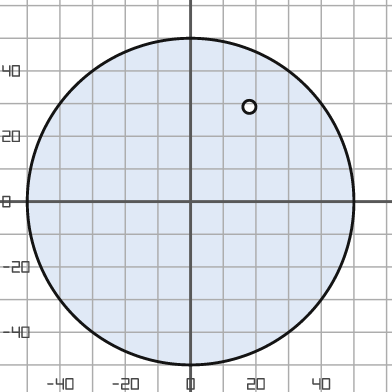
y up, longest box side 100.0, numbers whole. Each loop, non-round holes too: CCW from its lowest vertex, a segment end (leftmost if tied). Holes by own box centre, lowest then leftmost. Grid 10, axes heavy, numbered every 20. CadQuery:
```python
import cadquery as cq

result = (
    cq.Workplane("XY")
    .moveTo(0.0, 0.0)
    .circle(50.0)
    .moveTo(18.0, 29.0)
    .circle(2.0)
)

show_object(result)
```